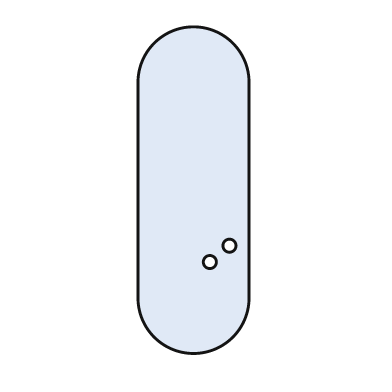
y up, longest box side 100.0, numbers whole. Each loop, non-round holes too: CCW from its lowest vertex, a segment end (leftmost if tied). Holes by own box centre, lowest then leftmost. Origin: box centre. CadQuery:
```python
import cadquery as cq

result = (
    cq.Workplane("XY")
    .moveTo(-17.0, -33.0)
    .threePointArc((0.0, -50.0), (17.0, -33.0))
    .lineTo(17.0, 33.0)
    .threePointArc((0.0, 50.0), (-17.0, 33.0))
    .close()
    .moveTo(5.0, -22.0)
    .circle(2.0)
    .moveTo(11.0, -17.0)
    .circle(2.0)
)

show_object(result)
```